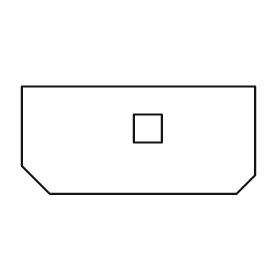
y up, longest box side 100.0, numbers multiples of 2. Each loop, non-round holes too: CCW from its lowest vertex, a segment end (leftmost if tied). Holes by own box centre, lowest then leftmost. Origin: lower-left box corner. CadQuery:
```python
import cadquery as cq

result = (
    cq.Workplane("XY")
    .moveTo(12.0, 0.0)
    .lineTo(92.0, 0.0)
    .lineTo(100.0, 8.0)
    .lineTo(100.0, 46.0)
    .lineTo(0.0, 46.0)
    .lineTo(0.0, 12.0)
    .close()
    .moveTo(48.0, 22.0)
    .lineTo(60.0, 22.0)
    .lineTo(60.0, 34.0)
    .lineTo(48.0, 34.0)
    .close()
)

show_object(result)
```